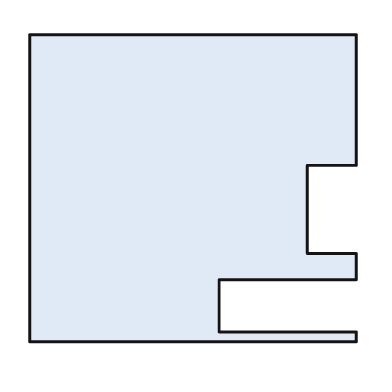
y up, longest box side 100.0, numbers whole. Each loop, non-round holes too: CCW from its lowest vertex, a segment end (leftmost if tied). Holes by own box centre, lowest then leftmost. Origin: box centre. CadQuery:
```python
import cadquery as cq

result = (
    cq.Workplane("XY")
    .moveTo(-50.0, -47.0)
    .lineTo(50.0, -47.0)
    .lineTo(50.0, -44.0)
    .lineTo(8.0, -44.0)
    .lineTo(8.0, -28.0)
    .lineTo(50.0, -28.0)
    .lineTo(50.0, -20.0)
    .lineTo(35.0, -20.0)
    .lineTo(35.0, 7.0)
    .lineTo(50.0, 7.0)
    .lineTo(50.0, 47.0)
    .lineTo(-50.0, 47.0)
    .close()
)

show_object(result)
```